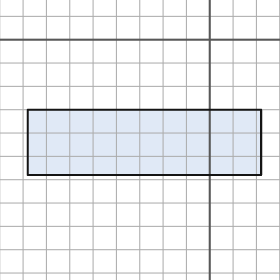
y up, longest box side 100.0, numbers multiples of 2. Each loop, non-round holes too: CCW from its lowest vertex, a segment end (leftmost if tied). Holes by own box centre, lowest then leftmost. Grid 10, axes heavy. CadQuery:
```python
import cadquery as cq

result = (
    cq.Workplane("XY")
    .moveTo(-78.0, -58.0)
    .lineTo(22.0, -58.0)
    .lineTo(22.0, -30.0)
    .lineTo(-78.0, -30.0)
    .close()
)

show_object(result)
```